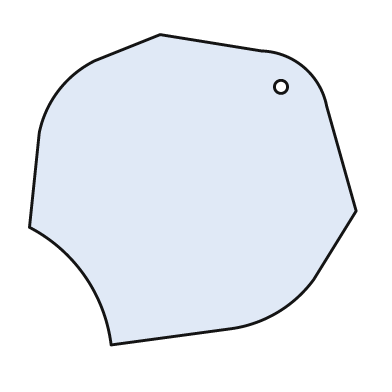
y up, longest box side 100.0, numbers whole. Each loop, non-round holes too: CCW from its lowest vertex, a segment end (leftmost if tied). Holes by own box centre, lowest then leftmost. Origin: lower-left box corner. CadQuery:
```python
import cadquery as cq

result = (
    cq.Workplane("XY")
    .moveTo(25.0, 0.0)
    .lineTo(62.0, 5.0)
    .threePointArc((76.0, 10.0), (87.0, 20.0))
    .lineTo(100.0, 41.0)
    .lineTo(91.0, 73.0)
    .threePointArc((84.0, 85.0), (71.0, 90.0))
    .lineTo(40.0, 95.0)
    .lineTo(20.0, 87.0)
    .threePointArc((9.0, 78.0), (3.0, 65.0))
    .lineTo(0.0, 36.0)
    .threePointArc((17.0, 21.0), (25.0, 0.0))
    .close()
    .moveTo(77.0, 79.0)
    .circle(2.0)
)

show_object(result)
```